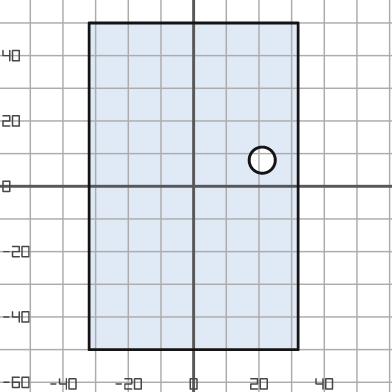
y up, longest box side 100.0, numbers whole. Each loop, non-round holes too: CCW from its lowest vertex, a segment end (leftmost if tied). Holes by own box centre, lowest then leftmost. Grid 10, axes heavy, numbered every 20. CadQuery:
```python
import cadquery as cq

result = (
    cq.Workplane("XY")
    .moveTo(-32.0, -50.0)
    .lineTo(32.0, -50.0)
    .lineTo(32.0, 50.0)
    .lineTo(-32.0, 50.0)
    .close()
    .moveTo(21.0, 8.0)
    .circle(4.0)
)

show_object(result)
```